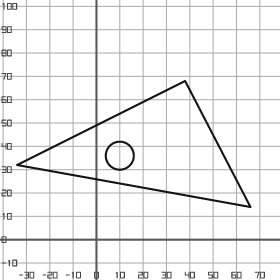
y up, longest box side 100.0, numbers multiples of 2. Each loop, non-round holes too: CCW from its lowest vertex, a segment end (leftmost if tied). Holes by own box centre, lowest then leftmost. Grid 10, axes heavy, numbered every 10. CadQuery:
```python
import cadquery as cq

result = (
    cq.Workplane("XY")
    .moveTo(66.0, 14.0)
    .lineTo(38.0, 68.0)
    .lineTo(-34.0, 32.0)
    .close()
    .moveTo(10.0, 36.0)
    .circle(6.0)
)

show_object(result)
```